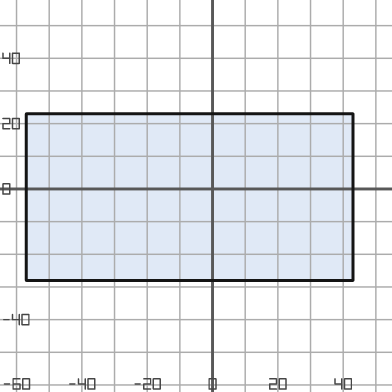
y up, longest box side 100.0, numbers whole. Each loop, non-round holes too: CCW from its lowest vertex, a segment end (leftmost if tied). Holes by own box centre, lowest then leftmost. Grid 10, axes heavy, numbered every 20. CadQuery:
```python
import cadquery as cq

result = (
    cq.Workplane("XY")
    .moveTo(-57.0, -28.0)
    .lineTo(43.0, -28.0)
    .lineTo(43.0, 23.0)
    .lineTo(-57.0, 23.0)
    .close()
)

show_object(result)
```